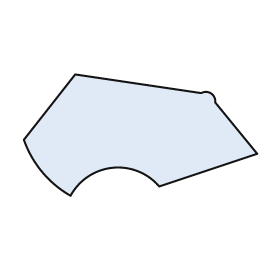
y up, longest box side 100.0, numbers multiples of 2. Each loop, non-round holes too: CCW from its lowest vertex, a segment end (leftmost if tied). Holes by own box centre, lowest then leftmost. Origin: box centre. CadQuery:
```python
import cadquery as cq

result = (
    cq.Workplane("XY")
    .moveTo(-30.0, -26.0)
    .threePointArc((-12.0, -14.0), (8.0, -22.0))
    .lineTo(50.0, -8.0)
    .lineTo(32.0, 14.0)
    .threePointArc((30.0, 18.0), (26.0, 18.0))
    .lineTo(-28.0, 26.0)
    .lineTo(-50.0, -2.0)
    .threePointArc((-42.0, -16.0), (-30.0, -26.0))
    .close()
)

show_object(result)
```